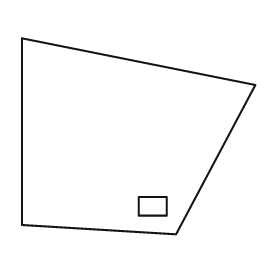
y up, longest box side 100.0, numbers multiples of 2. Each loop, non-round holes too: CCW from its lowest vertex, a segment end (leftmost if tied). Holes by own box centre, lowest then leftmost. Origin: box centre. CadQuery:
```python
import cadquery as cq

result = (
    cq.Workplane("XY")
    .moveTo(16.0, -42.0)
    .lineTo(50.0, 22.0)
    .lineTo(-50.0, 42.0)
    .lineTo(-50.0, -38.0)
    .close()
    .moveTo(0.0, -34.0)
    .lineTo(12.0, -34.0)
    .lineTo(12.0, -26.0)
    .lineTo(0.0, -26.0)
    .close()
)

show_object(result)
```